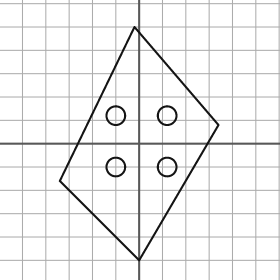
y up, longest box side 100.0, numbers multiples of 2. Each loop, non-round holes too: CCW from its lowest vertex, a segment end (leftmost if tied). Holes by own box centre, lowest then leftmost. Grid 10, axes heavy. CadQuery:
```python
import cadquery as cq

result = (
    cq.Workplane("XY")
    .moveTo(0.0, -50.0)
    .lineTo(34.0, 8.0)
    .lineTo(-2.0, 50.0)
    .lineTo(-34.0, -16.0)
    .close()
    .moveTo(-10.0, -10.0)
    .circle(4.0)
    .moveTo(12.0, -10.0)
    .circle(4.0)
    .moveTo(-10.0, 12.0)
    .circle(4.0)
    .moveTo(12.0, 12.0)
    .circle(4.0)
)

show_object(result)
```